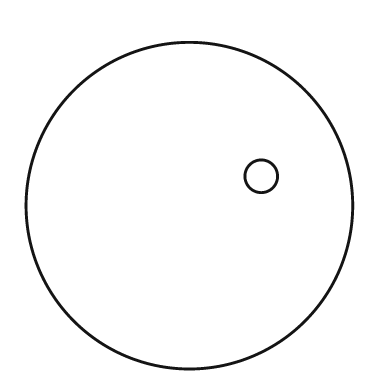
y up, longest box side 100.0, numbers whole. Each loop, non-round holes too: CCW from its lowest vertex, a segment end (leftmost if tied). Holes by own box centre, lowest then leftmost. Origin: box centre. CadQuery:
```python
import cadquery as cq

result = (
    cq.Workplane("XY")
    .moveTo(0.0, 0.0)
    .circle(50.0)
    .moveTo(22.0, 9.0)
    .circle(5.0)
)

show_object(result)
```